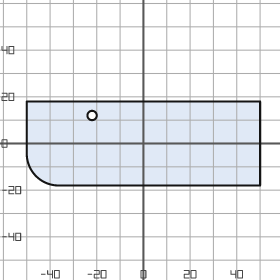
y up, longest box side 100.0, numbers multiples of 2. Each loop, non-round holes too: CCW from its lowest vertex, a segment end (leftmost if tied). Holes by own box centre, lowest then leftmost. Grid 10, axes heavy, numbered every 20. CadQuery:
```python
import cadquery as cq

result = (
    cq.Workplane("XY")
    .moveTo(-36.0, -18.0)
    .lineTo(50.0, -18.0)
    .lineTo(50.0, 18.0)
    .lineTo(-50.0, 18.0)
    .lineTo(-50.0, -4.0)
    .threePointArc((-46.0, -14.0), (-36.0, -18.0))
    .close()
    .moveTo(-22.0, 12.0)
    .circle(2.0)
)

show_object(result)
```